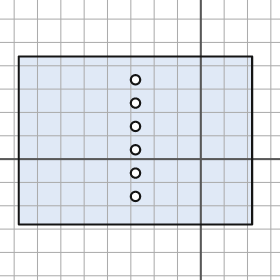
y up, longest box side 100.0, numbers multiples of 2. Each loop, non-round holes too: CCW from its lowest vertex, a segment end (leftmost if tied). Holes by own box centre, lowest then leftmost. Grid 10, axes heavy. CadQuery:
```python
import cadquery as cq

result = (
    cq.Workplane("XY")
    .moveTo(-78.0, -28.0)
    .lineTo(22.0, -28.0)
    .lineTo(22.0, 44.0)
    .lineTo(-78.0, 44.0)
    .close()
    .moveTo(-28.0, -16.0)
    .circle(2.0)
    .moveTo(-28.0, -6.0)
    .circle(2.0)
    .moveTo(-28.0, 4.0)
    .circle(2.0)
    .moveTo(-28.0, 14.0)
    .circle(2.0)
    .moveTo(-28.0, 24.0)
    .circle(2.0)
    .moveTo(-28.0, 34.0)
    .circle(2.0)
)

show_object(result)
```